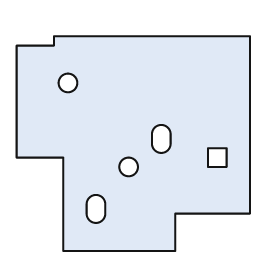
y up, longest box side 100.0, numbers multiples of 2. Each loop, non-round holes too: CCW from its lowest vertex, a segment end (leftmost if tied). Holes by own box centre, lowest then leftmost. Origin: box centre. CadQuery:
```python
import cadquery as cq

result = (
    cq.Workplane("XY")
    .moveTo(-30.0, -46.0)
    .lineTo(18.0, -46.0)
    .lineTo(18.0, -30.0)
    .lineTo(50.0, -30.0)
    .lineTo(50.0, 46.0)
    .lineTo(-34.0, 46.0)
    .lineTo(-34.0, 42.0)
    .lineTo(-50.0, 42.0)
    .lineTo(-50.0, -6.0)
    .lineTo(-30.0, -6.0)
    .close()
    .moveTo(-20.0, -30.0)
    .threePointArc((-16.0, -34.0), (-12.0, -30.0))
    .lineTo(-12.0, -26.0)
    .threePointArc((-16.0, -22.0), (-20.0, -26.0))
    .close()
    .moveTo(-2.0, -10.0)
    .circle(4.0)
    .moveTo(32.0, -10.0)
    .lineTo(40.0, -10.0)
    .lineTo(40.0, -2.0)
    .lineTo(32.0, -2.0)
    .close()
    .moveTo(8.0, 0.0)
    .threePointArc((12.0, -4.0), (16.0, 0.0))
    .lineTo(16.0, 4.0)
    .threePointArc((12.0, 8.0), (8.0, 4.0))
    .close()
    .moveTo(-28.0, 26.0)
    .circle(4.0)
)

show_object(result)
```